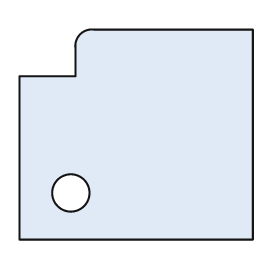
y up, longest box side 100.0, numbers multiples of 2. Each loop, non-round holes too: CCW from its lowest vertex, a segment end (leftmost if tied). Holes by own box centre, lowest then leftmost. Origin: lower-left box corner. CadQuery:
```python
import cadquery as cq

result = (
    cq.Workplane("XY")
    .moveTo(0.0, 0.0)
    .lineTo(100.0, 0.0)
    .lineTo(100.0, 90.0)
    .lineTo(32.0, 90.0)
    .threePointArc((26.0, 88.0), (24.0, 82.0))
    .lineTo(24.0, 70.0)
    .lineTo(0.0, 70.0)
    .close()
    .moveTo(22.0, 20.0)
    .circle(8.0)
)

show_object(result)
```